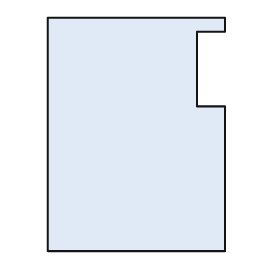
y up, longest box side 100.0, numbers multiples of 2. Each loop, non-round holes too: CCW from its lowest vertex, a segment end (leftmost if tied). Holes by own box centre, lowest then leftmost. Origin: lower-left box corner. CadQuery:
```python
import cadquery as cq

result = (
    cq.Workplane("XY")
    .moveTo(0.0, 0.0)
    .lineTo(76.0, 0.0)
    .lineTo(76.0, 62.0)
    .lineTo(64.0, 62.0)
    .lineTo(64.0, 94.0)
    .lineTo(76.0, 94.0)
    .lineTo(76.0, 100.0)
    .lineTo(0.0, 100.0)
    .close()
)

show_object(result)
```